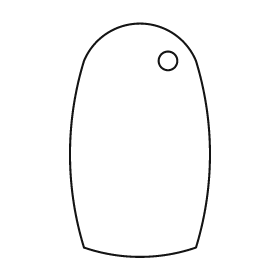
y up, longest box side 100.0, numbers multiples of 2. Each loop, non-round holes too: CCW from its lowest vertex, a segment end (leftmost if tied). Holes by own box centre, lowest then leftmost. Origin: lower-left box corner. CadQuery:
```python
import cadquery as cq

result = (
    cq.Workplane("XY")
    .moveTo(6.0, 4.0)
    .threePointArc((30.0, 0.0), (54.0, 4.0))
    .threePointArc((60.0, 44.0), (54.0, 84.0))
    .threePointArc((30.0, 100.0), (6.0, 84.0))
    .threePointArc((0.0, 44.0), (6.0, 4.0))
    .close()
    .moveTo(42.0, 84.0)
    .circle(4.0)
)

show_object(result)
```